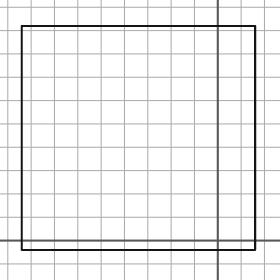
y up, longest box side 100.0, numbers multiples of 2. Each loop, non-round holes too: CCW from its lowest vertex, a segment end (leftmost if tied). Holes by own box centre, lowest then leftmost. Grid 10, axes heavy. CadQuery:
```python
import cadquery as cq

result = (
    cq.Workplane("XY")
    .moveTo(-84.0, -4.0)
    .lineTo(16.0, -4.0)
    .lineTo(16.0, 92.0)
    .lineTo(-84.0, 92.0)
    .close()
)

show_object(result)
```